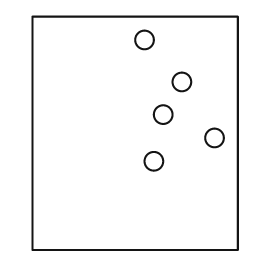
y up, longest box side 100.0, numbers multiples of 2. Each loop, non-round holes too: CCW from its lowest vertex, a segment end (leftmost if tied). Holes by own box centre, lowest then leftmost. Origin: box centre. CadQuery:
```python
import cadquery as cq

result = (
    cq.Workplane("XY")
    .moveTo(-44.0, -50.0)
    .lineTo(44.0, -50.0)
    .lineTo(44.0, 50.0)
    .lineTo(-44.0, 50.0)
    .close()
    .moveTo(8.0, -12.0)
    .circle(4.0)
    .moveTo(34.0, -2.0)
    .circle(4.0)
    .moveTo(12.0, 8.0)
    .circle(4.0)
    .moveTo(20.0, 22.0)
    .circle(4.0)
    .moveTo(4.0, 40.0)
    .circle(4.0)
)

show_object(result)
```